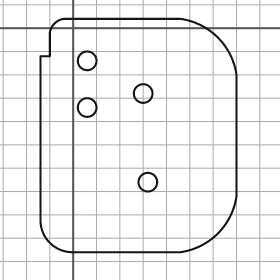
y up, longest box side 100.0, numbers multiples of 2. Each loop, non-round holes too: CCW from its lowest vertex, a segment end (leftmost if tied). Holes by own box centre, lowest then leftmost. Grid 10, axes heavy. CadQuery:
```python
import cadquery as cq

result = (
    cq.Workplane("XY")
    .moveTo(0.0, -96.0)
    .lineTo(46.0, -96.0)
    .threePointArc((62.0, -88.0), (70.0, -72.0))
    .lineTo(70.0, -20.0)
    .threePointArc((62.0, -4.0), (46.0, 4.0))
    .lineTo(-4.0, 4.0)
    .threePointArc((-8.0, 2.0), (-10.0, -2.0))
    .lineTo(-10.0, -12.0)
    .lineTo(-14.0, -12.0)
    .lineTo(-14.0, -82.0)
    .threePointArc((-10.0, -92.0), (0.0, -96.0))
    .close()
    .moveTo(32.0, -66.0)
    .circle(4.0)
    .moveTo(6.0, -34.0)
    .circle(4.0)
    .moveTo(30.0, -28.0)
    .circle(4.0)
    .moveTo(6.0, -14.0)
    .circle(4.0)
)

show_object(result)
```